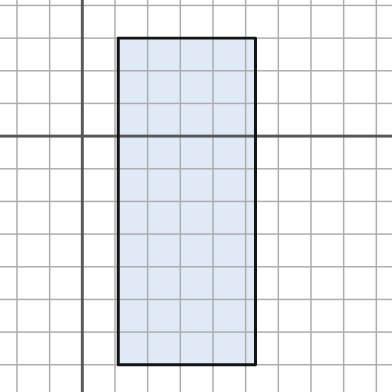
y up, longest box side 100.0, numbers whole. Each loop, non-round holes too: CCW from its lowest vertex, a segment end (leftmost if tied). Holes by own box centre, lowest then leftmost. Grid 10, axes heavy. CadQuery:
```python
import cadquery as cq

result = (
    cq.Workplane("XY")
    .moveTo(11.0, -70.0)
    .lineTo(53.0, -70.0)
    .lineTo(53.0, 30.0)
    .lineTo(11.0, 30.0)
    .close()
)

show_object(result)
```